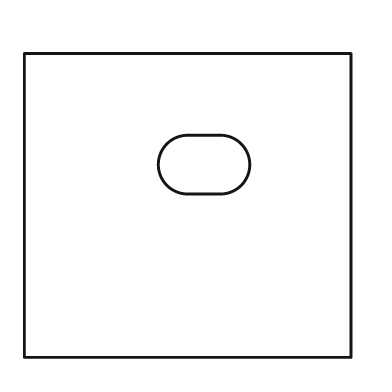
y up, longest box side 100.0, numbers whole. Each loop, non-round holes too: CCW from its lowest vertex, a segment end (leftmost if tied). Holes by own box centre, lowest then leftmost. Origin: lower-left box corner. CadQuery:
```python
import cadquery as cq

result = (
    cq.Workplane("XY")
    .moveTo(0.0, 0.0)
    .lineTo(100.0, 0.0)
    .lineTo(100.0, 93.0)
    .lineTo(0.0, 93.0)
    .close()
    .moveTo(50.0, 50.0)
    .lineTo(60.0, 50.0)
    .threePointArc((69.0, 59.0), (60.0, 68.0))
    .lineTo(50.0, 68.0)
    .threePointArc((41.0, 59.0), (50.0, 50.0))
    .close()
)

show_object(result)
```